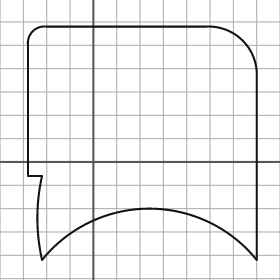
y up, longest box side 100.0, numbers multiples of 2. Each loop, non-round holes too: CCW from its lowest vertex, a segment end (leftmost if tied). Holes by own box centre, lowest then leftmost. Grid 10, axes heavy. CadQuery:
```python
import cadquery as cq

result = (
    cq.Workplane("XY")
    .moveTo(-22.0, -42.0)
    .threePointArc((24.0, -20.0), (70.0, -42.0))
    .lineTo(70.0, 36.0)
    .threePointArc((64.0, 52.0), (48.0, 58.0))
    .lineTo(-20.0, 58.0)
    .threePointArc((-26.0, 56.0), (-28.0, 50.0))
    .lineTo(-28.0, -6.0)
    .lineTo(-22.0, -6.0)
    .threePointArc((-24.0, -24.0), (-22.0, -42.0))
    .close()
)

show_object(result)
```